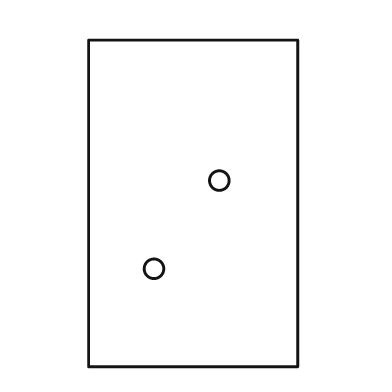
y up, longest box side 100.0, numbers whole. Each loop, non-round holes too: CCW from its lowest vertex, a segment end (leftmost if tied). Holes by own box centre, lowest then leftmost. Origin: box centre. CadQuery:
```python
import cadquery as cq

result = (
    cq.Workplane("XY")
    .moveTo(-32.0, -50.0)
    .lineTo(32.0, -50.0)
    .lineTo(32.0, 50.0)
    .lineTo(-32.0, 50.0)
    .close()
    .moveTo(-12.0, -20.0)
    .circle(3.0)
    .moveTo(8.0, 7.0)
    .circle(3.0)
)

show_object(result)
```